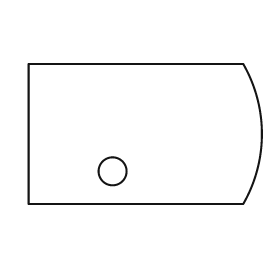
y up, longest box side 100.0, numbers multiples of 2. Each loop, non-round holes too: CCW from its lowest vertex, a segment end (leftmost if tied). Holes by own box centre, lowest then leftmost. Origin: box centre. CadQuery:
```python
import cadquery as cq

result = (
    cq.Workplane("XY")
    .moveTo(-50.0, -30.0)
    .lineTo(42.0, -30.0)
    .threePointArc((50.0, 0.0), (42.0, 30.0))
    .lineTo(-50.0, 30.0)
    .close()
    .moveTo(-14.0, -16.0)
    .circle(6.0)
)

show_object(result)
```